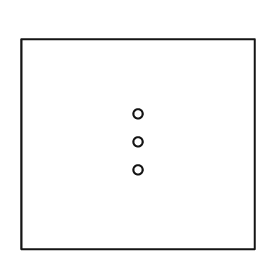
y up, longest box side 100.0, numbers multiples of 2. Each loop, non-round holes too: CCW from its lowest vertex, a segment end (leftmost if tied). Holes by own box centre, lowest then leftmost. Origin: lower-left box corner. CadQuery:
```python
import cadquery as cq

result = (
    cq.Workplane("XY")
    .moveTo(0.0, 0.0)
    .lineTo(100.0, 0.0)
    .lineTo(100.0, 90.0)
    .lineTo(0.0, 90.0)
    .close()
    .moveTo(50.0, 34.0)
    .circle(2.0)
    .moveTo(50.0, 46.0)
    .circle(2.0)
    .moveTo(50.0, 58.0)
    .circle(2.0)
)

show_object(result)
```